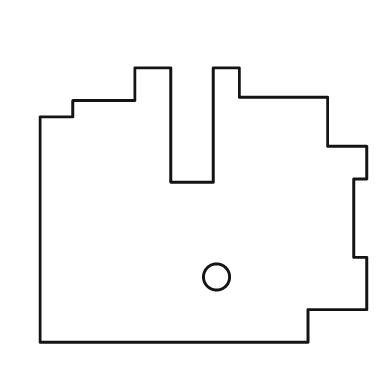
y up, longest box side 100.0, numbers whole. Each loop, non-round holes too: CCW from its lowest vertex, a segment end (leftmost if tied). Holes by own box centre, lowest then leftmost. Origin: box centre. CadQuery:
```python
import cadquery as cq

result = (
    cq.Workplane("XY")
    .moveTo(-50.0, -42.0)
    .lineTo(32.0, -42.0)
    .lineTo(32.0, -32.0)
    .lineTo(50.0, -32.0)
    .lineTo(50.0, -16.0)
    .lineTo(46.0, -16.0)
    .lineTo(46.0, 8.0)
    .lineTo(50.0, 8.0)
    .lineTo(50.0, 18.0)
    .lineTo(38.0, 18.0)
    .lineTo(38.0, 33.0)
    .lineTo(11.0, 33.0)
    .lineTo(11.0, 42.0)
    .lineTo(3.0, 42.0)
    .lineTo(3.0, 7.0)
    .lineTo(-10.0, 7.0)
    .lineTo(-10.0, 42.0)
    .lineTo(-21.0, 42.0)
    .lineTo(-21.0, 32.0)
    .lineTo(-40.0, 32.0)
    .lineTo(-40.0, 27.0)
    .lineTo(-50.0, 27.0)
    .close()
    .moveTo(4.0, -22.0)
    .circle(4.0)
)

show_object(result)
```